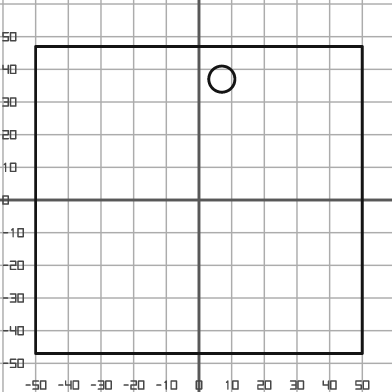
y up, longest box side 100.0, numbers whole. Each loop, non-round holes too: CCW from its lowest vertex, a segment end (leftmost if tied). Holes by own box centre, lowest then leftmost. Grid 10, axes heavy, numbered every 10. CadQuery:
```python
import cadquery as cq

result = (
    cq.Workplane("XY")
    .moveTo(-50.0, -47.0)
    .lineTo(50.0, -47.0)
    .lineTo(50.0, 47.0)
    .lineTo(-50.0, 47.0)
    .close()
    .moveTo(7.0, 37.0)
    .circle(4.0)
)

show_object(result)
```